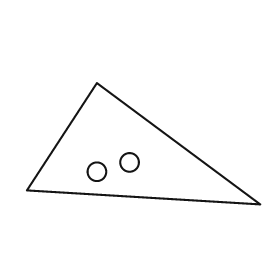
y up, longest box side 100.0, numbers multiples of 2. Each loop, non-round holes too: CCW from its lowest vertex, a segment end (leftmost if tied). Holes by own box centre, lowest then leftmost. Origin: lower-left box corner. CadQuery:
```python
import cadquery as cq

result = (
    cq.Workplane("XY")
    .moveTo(100.0, 0.0)
    .lineTo(30.0, 52.0)
    .lineTo(0.0, 6.0)
    .close()
    .moveTo(30.0, 14.0)
    .circle(4.0)
    .moveTo(44.0, 18.0)
    .circle(4.0)
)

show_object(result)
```